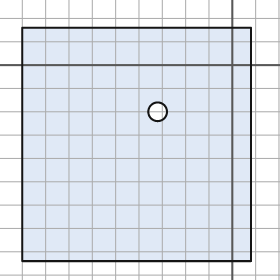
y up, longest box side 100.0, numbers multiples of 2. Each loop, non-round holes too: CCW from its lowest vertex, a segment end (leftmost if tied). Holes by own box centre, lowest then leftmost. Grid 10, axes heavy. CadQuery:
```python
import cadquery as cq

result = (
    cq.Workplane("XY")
    .moveTo(-90.0, -84.0)
    .lineTo(8.0, -84.0)
    .lineTo(8.0, 16.0)
    .lineTo(-90.0, 16.0)
    .close()
    .moveTo(-32.0, -20.0)
    .circle(4.0)
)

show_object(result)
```